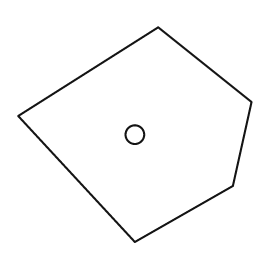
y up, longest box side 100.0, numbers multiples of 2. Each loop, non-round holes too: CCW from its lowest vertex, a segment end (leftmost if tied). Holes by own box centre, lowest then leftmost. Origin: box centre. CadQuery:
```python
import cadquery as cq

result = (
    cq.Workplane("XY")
    .moveTo(0.0, -46.0)
    .lineTo(42.0, -22.0)
    .lineTo(50.0, 14.0)
    .lineTo(10.0, 46.0)
    .lineTo(-50.0, 8.0)
    .close()
    .moveTo(0.0, 0.0)
    .circle(4.0)
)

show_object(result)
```